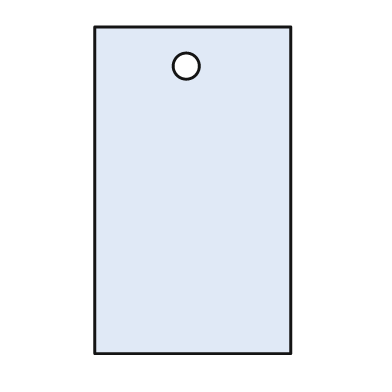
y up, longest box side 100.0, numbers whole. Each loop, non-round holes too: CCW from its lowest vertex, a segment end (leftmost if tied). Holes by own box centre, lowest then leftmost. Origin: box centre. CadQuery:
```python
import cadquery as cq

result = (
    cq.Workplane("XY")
    .moveTo(-30.0, -50.0)
    .lineTo(30.0, -50.0)
    .lineTo(30.0, 50.0)
    .lineTo(-30.0, 50.0)
    .close()
    .moveTo(-2.0, 38.0)
    .circle(4.0)
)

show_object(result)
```